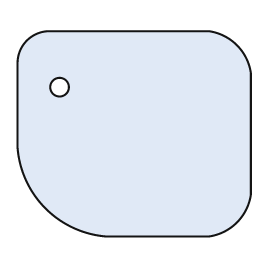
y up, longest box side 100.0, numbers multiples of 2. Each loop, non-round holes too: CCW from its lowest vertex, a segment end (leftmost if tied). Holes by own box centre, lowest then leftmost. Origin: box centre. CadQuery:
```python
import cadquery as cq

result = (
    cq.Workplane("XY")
    .moveTo(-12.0, -44.0)
    .lineTo(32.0, -44.0)
    .threePointArc((44.0, -38.0), (50.0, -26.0))
    .lineTo(50.0, 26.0)
    .threePointArc((44.0, 38.0), (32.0, 44.0))
    .lineTo(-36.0, 44.0)
    .threePointArc((-46.0, 40.0), (-50.0, 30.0))
    .lineTo(-50.0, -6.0)
    .threePointArc((-38.0, -32.0), (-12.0, -44.0))
    .close()
    .moveTo(-32.0, 20.0)
    .circle(4.0)
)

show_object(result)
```